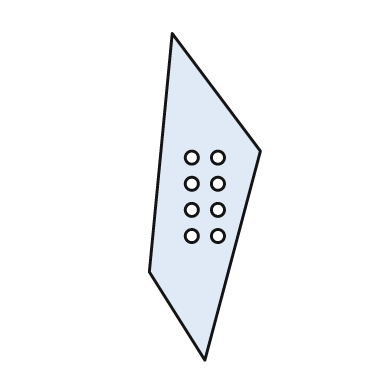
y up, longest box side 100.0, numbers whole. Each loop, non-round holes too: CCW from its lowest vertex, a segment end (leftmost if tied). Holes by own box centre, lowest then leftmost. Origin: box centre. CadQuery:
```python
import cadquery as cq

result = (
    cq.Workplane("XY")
    .moveTo(0.0, -50.0)
    .lineTo(17.0, 14.0)
    .lineTo(-10.0, 50.0)
    .lineTo(-17.0, -23.0)
    .close()
    .moveTo(-4.0, -12.0)
    .circle(2.0)
    .moveTo(4.0, -12.0)
    .circle(2.0)
    .moveTo(-4.0, -4.0)
    .circle(2.0)
    .moveTo(4.0, -4.0)
    .circle(2.0)
    .moveTo(-4.0, 4.0)
    .circle(2.0)
    .moveTo(4.0, 4.0)
    .circle(2.0)
    .moveTo(-4.0, 12.0)
    .circle(2.0)
    .moveTo(4.0, 12.0)
    .circle(2.0)
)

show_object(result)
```